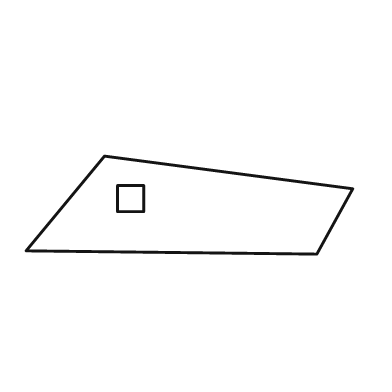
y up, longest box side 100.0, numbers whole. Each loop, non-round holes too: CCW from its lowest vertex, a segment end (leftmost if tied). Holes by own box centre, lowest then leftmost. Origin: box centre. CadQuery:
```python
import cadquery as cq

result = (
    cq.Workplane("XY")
    .moveTo(39.0, -15.0)
    .lineTo(50.0, 5.0)
    .lineTo(-26.0, 15.0)
    .lineTo(-50.0, -14.0)
    .close()
    .moveTo(-22.0, -2.0)
    .lineTo(-14.0, -2.0)
    .lineTo(-14.0, 6.0)
    .lineTo(-22.0, 6.0)
    .close()
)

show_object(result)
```